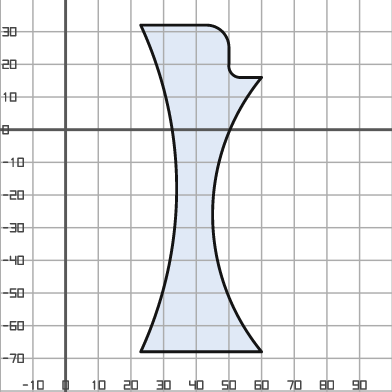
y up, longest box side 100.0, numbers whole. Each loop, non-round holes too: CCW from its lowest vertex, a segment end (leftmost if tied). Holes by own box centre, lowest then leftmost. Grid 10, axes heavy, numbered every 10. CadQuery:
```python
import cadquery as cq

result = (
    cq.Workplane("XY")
    .moveTo(23.0, -68.0)
    .lineTo(60.0, -68.0)
    .threePointArc((45.0, -26.0), (60.0, 16.0))
    .lineTo(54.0, 16.0)
    .threePointArc((51.0, 17.0), (50.0, 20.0))
    .lineTo(50.0, 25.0)
    .threePointArc((48.0, 30.0), (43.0, 32.0))
    .lineTo(23.0, 32.0)
    .threePointArc((34.0, -18.0), (23.0, -68.0))
    .close()
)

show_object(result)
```